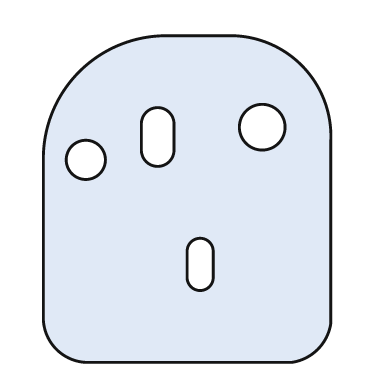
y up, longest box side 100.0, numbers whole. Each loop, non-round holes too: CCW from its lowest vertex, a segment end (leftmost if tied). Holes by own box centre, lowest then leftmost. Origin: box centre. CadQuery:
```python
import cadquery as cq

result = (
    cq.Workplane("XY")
    .moveTo(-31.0, -50.0)
    .lineTo(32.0, -50.0)
    .threePointArc((40.0, -46.0), (44.0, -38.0))
    .lineTo(44.0, 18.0)
    .threePointArc((35.0, 41.0), (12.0, 50.0))
    .lineTo(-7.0, 50.0)
    .threePointArc((-33.0, 39.0), (-44.0, 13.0))
    .lineTo(-44.0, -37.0)
    .threePointArc((-40.0, -46.0), (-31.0, -50.0))
    .close()
    .moveTo(0.0, -24.0)
    .threePointArc((4.0, -28.0), (8.0, -24.0))
    .lineTo(8.0, -16.0)
    .threePointArc((4.0, -12.0), (0.0, -16.0))
    .close()
    .moveTo(-31.0, 12.0)
    .circle(6.0)
    .moveTo(-14.0, 15.0)
    .threePointArc((-9.0, 10.0), (-4.0, 15.0))
    .lineTo(-4.0, 23.0)
    .threePointArc((-9.0, 28.0), (-14.0, 23.0))
    .close()
    .moveTo(23.0, 22.0)
    .circle(7.0)
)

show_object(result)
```